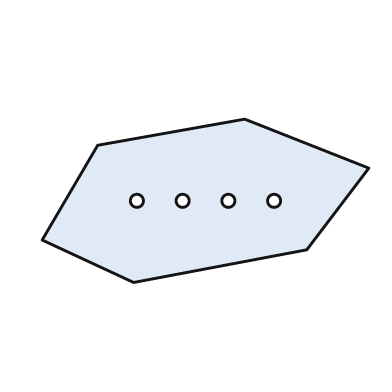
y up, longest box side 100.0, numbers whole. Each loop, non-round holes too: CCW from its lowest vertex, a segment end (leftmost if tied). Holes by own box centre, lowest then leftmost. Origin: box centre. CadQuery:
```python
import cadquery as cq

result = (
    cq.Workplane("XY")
    .moveTo(-22.0, -25.0)
    .lineTo(31.0, -15.0)
    .lineTo(50.0, 10.0)
    .lineTo(12.0, 25.0)
    .lineTo(-33.0, 17.0)
    .lineTo(-50.0, -12.0)
    .close()
    .moveTo(-21.0, 0.0)
    .circle(2.0)
    .moveTo(-7.0, 0.0)
    .circle(2.0)
    .moveTo(7.0, 0.0)
    .circle(2.0)
    .moveTo(21.0, 0.0)
    .circle(2.0)
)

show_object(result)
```